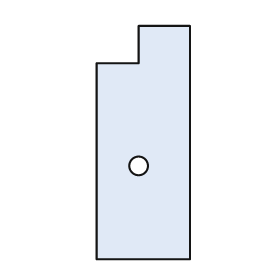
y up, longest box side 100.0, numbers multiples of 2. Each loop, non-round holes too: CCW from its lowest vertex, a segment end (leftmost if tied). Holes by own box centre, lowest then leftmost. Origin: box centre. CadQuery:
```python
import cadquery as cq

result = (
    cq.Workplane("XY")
    .moveTo(-20.0, -50.0)
    .lineTo(20.0, -50.0)
    .lineTo(20.0, 50.0)
    .lineTo(-2.0, 50.0)
    .lineTo(-2.0, 34.0)
    .lineTo(-20.0, 34.0)
    .close()
    .moveTo(-2.0, -10.0)
    .circle(4.0)
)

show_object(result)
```